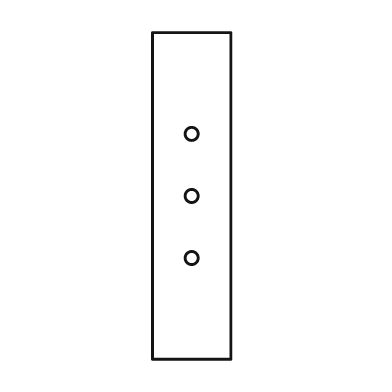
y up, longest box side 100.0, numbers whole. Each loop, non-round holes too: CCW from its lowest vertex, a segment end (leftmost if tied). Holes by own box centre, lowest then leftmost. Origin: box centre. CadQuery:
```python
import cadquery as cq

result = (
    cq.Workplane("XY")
    .moveTo(-12.0, -50.0)
    .lineTo(12.0, -50.0)
    .lineTo(12.0, 50.0)
    .lineTo(-12.0, 50.0)
    .close()
    .moveTo(0.0, -19.0)
    .circle(2.0)
    .moveTo(0.0, 0.0)
    .circle(2.0)
    .moveTo(0.0, 19.0)
    .circle(2.0)
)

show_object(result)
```